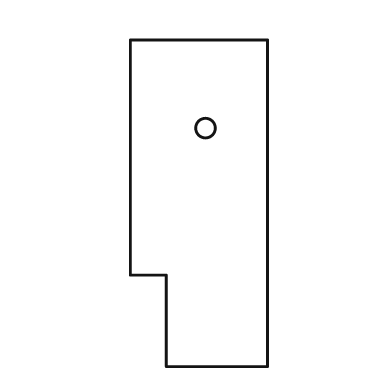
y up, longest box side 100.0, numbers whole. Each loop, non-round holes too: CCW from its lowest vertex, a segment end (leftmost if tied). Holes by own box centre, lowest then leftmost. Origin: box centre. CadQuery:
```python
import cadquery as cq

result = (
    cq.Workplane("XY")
    .moveTo(-10.0, -50.0)
    .lineTo(21.0, -50.0)
    .lineTo(21.0, 50.0)
    .lineTo(-21.0, 50.0)
    .lineTo(-21.0, -22.0)
    .lineTo(-10.0, -22.0)
    .close()
    .moveTo(2.0, 23.0)
    .circle(3.0)
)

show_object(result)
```